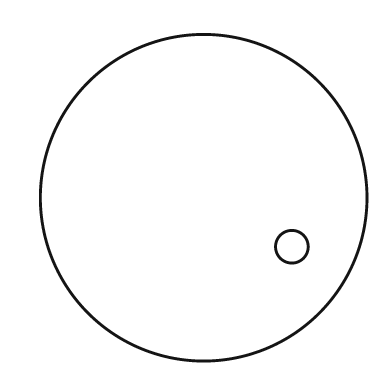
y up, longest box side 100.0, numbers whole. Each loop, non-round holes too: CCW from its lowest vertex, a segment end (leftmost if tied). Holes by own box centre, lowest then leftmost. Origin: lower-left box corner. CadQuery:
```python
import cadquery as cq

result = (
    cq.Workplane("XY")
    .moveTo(50.0, 50.0)
    .circle(50.0)
    .moveTo(77.0, 35.0)
    .circle(5.0)
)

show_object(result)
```